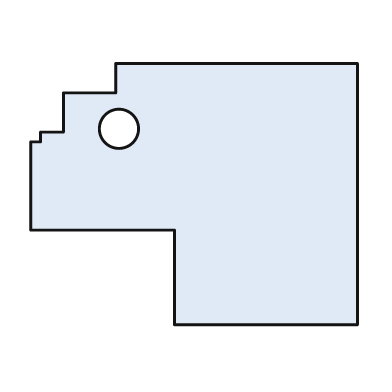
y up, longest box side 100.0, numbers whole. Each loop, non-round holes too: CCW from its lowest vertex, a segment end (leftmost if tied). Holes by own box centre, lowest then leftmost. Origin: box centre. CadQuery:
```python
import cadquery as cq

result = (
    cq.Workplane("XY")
    .moveTo(-6.0, -40.0)
    .lineTo(50.0, -40.0)
    .lineTo(50.0, 40.0)
    .lineTo(-24.0, 40.0)
    .lineTo(-24.0, 31.0)
    .lineTo(-40.0, 31.0)
    .lineTo(-40.0, 19.0)
    .lineTo(-47.0, 19.0)
    .lineTo(-47.0, 16.0)
    .lineTo(-50.0, 16.0)
    .lineTo(-50.0, -11.0)
    .lineTo(-6.0, -11.0)
    .close()
    .moveTo(-23.0, 20.0)
    .circle(6.0)
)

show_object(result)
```